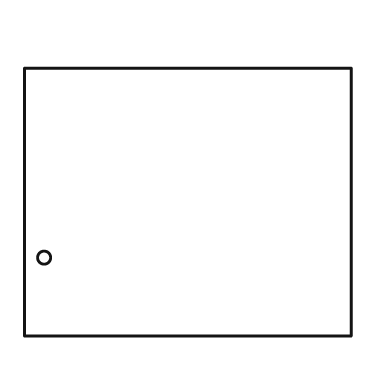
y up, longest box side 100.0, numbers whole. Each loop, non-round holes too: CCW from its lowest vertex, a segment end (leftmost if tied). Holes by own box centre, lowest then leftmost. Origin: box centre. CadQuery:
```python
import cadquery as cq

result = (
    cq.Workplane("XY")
    .moveTo(-50.0, -41.0)
    .lineTo(50.0, -41.0)
    .lineTo(50.0, 41.0)
    .lineTo(-50.0, 41.0)
    .close()
    .moveTo(-44.0, -17.0)
    .circle(2.0)
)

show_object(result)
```